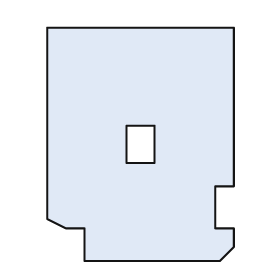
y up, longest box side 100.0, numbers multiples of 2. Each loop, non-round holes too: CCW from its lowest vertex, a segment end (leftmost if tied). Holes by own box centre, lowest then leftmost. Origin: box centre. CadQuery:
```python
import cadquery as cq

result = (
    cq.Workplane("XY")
    .moveTo(-24.0, -50.0)
    .lineTo(34.0, -50.0)
    .lineTo(40.0, -44.0)
    .lineTo(40.0, -36.0)
    .lineTo(32.0, -36.0)
    .lineTo(32.0, -18.0)
    .lineTo(40.0, -18.0)
    .lineTo(40.0, 50.0)
    .lineTo(-40.0, 50.0)
    .lineTo(-40.0, -32.0)
    .lineTo(-32.0, -36.0)
    .lineTo(-24.0, -36.0)
    .close()
    .moveTo(-6.0, -8.0)
    .lineTo(6.0, -8.0)
    .lineTo(6.0, 8.0)
    .lineTo(-6.0, 8.0)
    .close()
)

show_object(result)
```